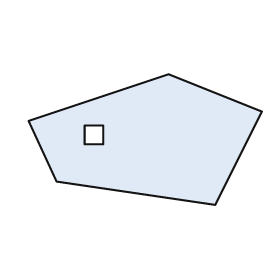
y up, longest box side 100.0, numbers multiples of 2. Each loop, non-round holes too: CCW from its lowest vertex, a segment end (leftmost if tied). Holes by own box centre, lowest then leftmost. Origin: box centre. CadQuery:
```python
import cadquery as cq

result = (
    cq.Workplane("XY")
    .moveTo(30.0, -28.0)
    .lineTo(50.0, 12.0)
    .lineTo(10.0, 28.0)
    .lineTo(-50.0, 8.0)
    .lineTo(-38.0, -18.0)
    .close()
    .moveTo(-26.0, -2.0)
    .lineTo(-18.0, -2.0)
    .lineTo(-18.0, 6.0)
    .lineTo(-26.0, 6.0)
    .close()
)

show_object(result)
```